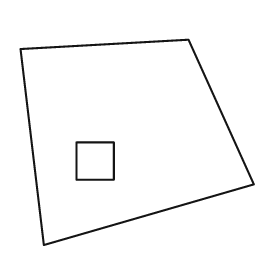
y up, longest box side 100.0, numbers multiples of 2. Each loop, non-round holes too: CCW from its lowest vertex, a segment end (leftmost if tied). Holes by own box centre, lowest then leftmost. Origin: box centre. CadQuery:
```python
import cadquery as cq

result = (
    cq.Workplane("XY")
    .moveTo(-40.0, -44.0)
    .lineTo(50.0, -18.0)
    .lineTo(22.0, 44.0)
    .lineTo(-50.0, 40.0)
    .close()
    .moveTo(-26.0, -16.0)
    .lineTo(-10.0, -16.0)
    .lineTo(-10.0, 0.0)
    .lineTo(-26.0, 0.0)
    .close()
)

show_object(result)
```